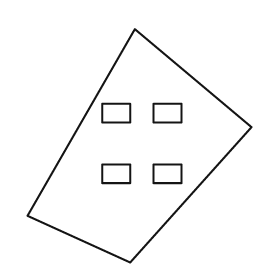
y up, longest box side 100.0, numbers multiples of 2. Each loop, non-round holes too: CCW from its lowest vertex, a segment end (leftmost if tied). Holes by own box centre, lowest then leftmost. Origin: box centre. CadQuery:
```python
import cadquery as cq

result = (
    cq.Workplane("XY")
    .moveTo(-4.0, -50.0)
    .lineTo(48.0, 8.0)
    .lineTo(-2.0, 50.0)
    .lineTo(-48.0, -30.0)
    .close()
    .moveTo(-16.0, -16.0)
    .lineTo(-4.0, -16.0)
    .lineTo(-4.0, -8.0)
    .lineTo(-16.0, -8.0)
    .close()
    .moveTo(6.0, -16.0)
    .lineTo(18.0, -16.0)
    .lineTo(18.0, -8.0)
    .lineTo(6.0, -8.0)
    .close()
    .moveTo(-16.0, 10.0)
    .lineTo(-4.0, 10.0)
    .lineTo(-4.0, 18.0)
    .lineTo(-16.0, 18.0)
    .close()
    .moveTo(6.0, 10.0)
    .lineTo(18.0, 10.0)
    .lineTo(18.0, 18.0)
    .lineTo(6.0, 18.0)
    .close()
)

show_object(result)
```